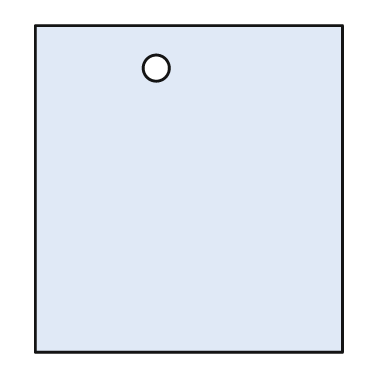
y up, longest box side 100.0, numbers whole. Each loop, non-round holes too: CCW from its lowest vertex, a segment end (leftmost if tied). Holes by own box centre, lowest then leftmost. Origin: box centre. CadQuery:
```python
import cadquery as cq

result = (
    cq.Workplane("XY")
    .moveTo(-47.0, -50.0)
    .lineTo(47.0, -50.0)
    .lineTo(47.0, 50.0)
    .lineTo(-47.0, 50.0)
    .close()
    .moveTo(-10.0, 37.0)
    .circle(4.0)
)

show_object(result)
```